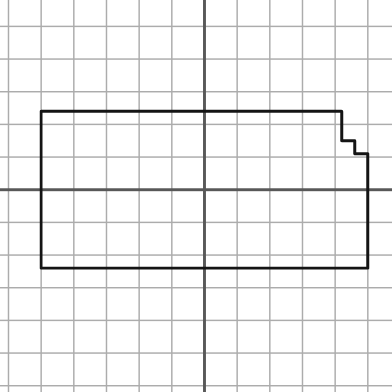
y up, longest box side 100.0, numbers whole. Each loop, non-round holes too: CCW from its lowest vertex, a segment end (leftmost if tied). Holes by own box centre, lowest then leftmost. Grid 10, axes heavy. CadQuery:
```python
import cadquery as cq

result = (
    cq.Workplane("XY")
    .moveTo(-50.0, -24.0)
    .lineTo(50.0, -24.0)
    .lineTo(50.0, 11.0)
    .lineTo(46.0, 11.0)
    .lineTo(46.0, 15.0)
    .lineTo(42.0, 15.0)
    .lineTo(42.0, 24.0)
    .lineTo(-50.0, 24.0)
    .close()
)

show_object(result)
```